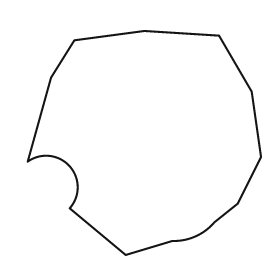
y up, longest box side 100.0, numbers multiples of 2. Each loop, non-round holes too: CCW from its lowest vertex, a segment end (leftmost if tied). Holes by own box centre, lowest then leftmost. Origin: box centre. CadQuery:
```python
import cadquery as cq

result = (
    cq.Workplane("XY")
    .moveTo(-8.0, -48.0)
    .lineTo(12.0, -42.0)
    .threePointArc((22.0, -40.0), (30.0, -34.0))
    .lineTo(40.0, -26.0)
    .lineTo(50.0, -6.0)
    .lineTo(46.0, 22.0)
    .lineTo(32.0, 46.0)
    .lineTo(0.0, 48.0)
    .lineTo(-30.0, 44.0)
    .lineTo(-40.0, 28.0)
    .lineTo(-50.0, -8.0)
    .threePointArc((-32.0, -10.0), (-32.0, -28.0))
    .close()
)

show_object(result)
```